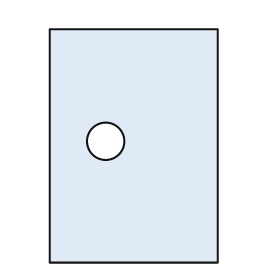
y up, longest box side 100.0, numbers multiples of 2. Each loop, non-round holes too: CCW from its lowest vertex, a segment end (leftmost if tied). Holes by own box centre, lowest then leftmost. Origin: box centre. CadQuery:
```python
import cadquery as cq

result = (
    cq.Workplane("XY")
    .moveTo(-36.0, -50.0)
    .lineTo(36.0, -50.0)
    .lineTo(36.0, 50.0)
    .lineTo(-36.0, 50.0)
    .close()
    .moveTo(-12.0, 2.0)
    .circle(8.0)
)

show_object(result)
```